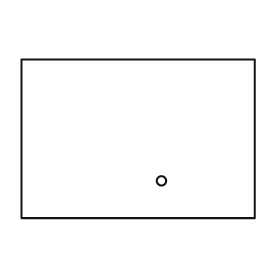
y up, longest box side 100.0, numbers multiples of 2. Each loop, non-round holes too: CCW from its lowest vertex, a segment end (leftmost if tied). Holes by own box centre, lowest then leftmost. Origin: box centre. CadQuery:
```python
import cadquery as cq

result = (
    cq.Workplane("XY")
    .moveTo(-50.0, -34.0)
    .lineTo(50.0, -34.0)
    .lineTo(50.0, 34.0)
    .lineTo(-50.0, 34.0)
    .close()
    .moveTo(10.0, -18.0)
    .circle(2.0)
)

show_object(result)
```